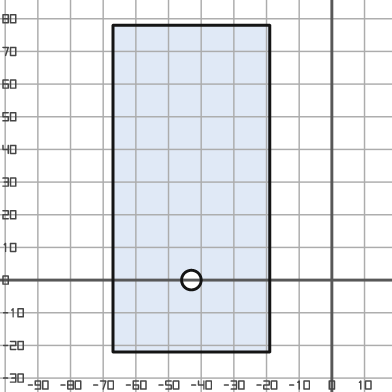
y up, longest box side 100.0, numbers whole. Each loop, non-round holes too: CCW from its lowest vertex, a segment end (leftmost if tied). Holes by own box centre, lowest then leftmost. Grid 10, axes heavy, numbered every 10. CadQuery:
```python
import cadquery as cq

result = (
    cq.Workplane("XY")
    .moveTo(-67.0, -22.0)
    .lineTo(-19.0, -22.0)
    .lineTo(-19.0, 78.0)
    .lineTo(-67.0, 78.0)
    .close()
    .moveTo(-43.0, 0.0)
    .circle(3.0)
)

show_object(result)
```